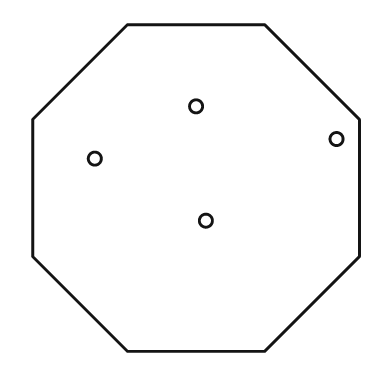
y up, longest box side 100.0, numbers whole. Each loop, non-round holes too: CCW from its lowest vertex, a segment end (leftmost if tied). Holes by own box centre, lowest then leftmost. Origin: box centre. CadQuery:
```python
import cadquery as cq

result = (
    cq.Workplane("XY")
    .moveTo(-21.0, -50.0)
    .lineTo(21.0, -50.0)
    .lineTo(50.0, -21.0)
    .lineTo(50.0, 21.0)
    .lineTo(21.0, 50.0)
    .lineTo(-21.0, 50.0)
    .lineTo(-50.0, 21.0)
    .lineTo(-50.0, -21.0)
    .close()
    .moveTo(3.0, -10.0)
    .circle(2.0)
    .moveTo(-31.0, 9.0)
    .circle(2.0)
    .moveTo(43.0, 15.0)
    .circle(2.0)
    .moveTo(0.0, 25.0)
    .circle(2.0)
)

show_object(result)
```